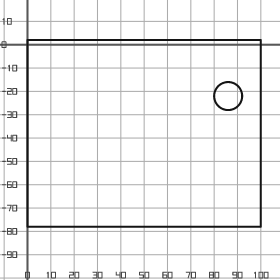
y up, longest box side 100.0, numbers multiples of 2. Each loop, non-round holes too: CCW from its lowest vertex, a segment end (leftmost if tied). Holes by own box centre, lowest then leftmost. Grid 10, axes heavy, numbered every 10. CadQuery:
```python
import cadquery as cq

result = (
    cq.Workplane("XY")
    .moveTo(0.0, -78.0)
    .lineTo(100.0, -78.0)
    .lineTo(100.0, 2.0)
    .lineTo(0.0, 2.0)
    .close()
    .moveTo(86.0, -22.0)
    .circle(6.0)
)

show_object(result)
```